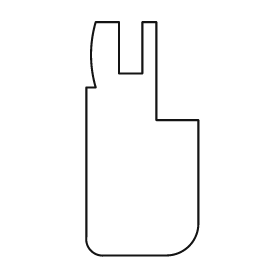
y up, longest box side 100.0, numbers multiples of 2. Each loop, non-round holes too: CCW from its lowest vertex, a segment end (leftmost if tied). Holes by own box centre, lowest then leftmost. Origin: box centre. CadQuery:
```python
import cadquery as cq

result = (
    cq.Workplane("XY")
    .moveTo(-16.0, -50.0)
    .lineTo(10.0, -50.0)
    .threePointArc((20.0, -46.0), (24.0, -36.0))
    .lineTo(24.0, 8.0)
    .lineTo(6.0, 8.0)
    .lineTo(6.0, 50.0)
    .lineTo(0.0, 50.0)
    .lineTo(0.0, 28.0)
    .lineTo(-10.0, 28.0)
    .lineTo(-10.0, 50.0)
    .lineTo(-20.0, 50.0)
    .threePointArc((-22.0, 36.0), (-20.0, 22.0))
    .lineTo(-24.0, 22.0)
    .lineTo(-24.0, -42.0)
    .threePointArc((-22.0, -48.0), (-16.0, -50.0))
    .close()
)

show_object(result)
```